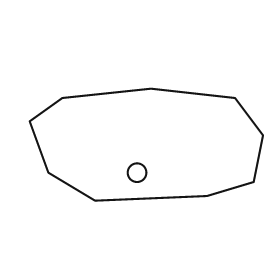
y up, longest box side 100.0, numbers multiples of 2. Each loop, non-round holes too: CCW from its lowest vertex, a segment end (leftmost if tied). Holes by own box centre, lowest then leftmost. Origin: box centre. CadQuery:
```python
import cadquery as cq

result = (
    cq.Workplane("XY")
    .moveTo(-22.0, -24.0)
    .lineTo(26.0, -22.0)
    .lineTo(46.0, -16.0)
    .lineTo(50.0, 4.0)
    .lineTo(38.0, 20.0)
    .lineTo(2.0, 24.0)
    .lineTo(-36.0, 20.0)
    .lineTo(-50.0, 10.0)
    .lineTo(-42.0, -12.0)
    .close()
    .moveTo(-4.0, -12.0)
    .circle(4.0)
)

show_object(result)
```